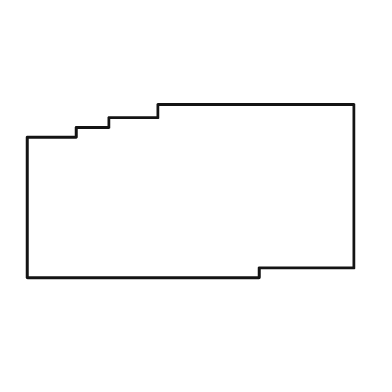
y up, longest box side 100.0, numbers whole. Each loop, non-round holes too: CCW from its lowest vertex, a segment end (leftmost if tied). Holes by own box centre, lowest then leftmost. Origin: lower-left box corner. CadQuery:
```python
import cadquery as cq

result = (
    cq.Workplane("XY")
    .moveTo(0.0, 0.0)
    .lineTo(71.0, 0.0)
    .lineTo(71.0, 3.0)
    .lineTo(100.0, 3.0)
    .lineTo(100.0, 53.0)
    .lineTo(40.0, 53.0)
    .lineTo(40.0, 49.0)
    .lineTo(25.0, 49.0)
    .lineTo(25.0, 46.0)
    .lineTo(15.0, 46.0)
    .lineTo(15.0, 43.0)
    .lineTo(0.0, 43.0)
    .close()
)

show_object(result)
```